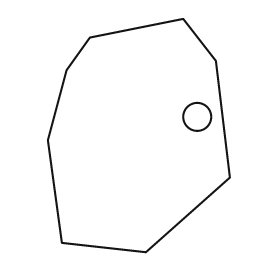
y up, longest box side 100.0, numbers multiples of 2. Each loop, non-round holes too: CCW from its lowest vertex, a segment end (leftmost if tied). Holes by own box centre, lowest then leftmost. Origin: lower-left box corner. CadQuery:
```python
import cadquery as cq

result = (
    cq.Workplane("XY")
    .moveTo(42.0, 0.0)
    .lineTo(78.0, 32.0)
    .lineTo(72.0, 82.0)
    .lineTo(58.0, 100.0)
    .lineTo(18.0, 92.0)
    .lineTo(8.0, 78.0)
    .lineTo(0.0, 48.0)
    .lineTo(6.0, 4.0)
    .close()
    .moveTo(64.0, 58.0)
    .circle(6.0)
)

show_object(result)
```